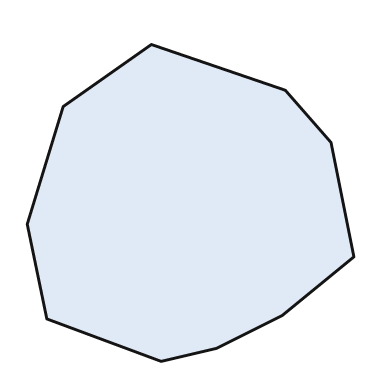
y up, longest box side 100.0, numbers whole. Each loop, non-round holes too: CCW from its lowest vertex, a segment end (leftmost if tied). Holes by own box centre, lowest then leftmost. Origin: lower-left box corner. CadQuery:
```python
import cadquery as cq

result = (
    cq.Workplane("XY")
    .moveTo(41.0, 0.0)
    .lineTo(58.0, 4.0)
    .lineTo(78.0, 14.0)
    .lineTo(100.0, 32.0)
    .lineTo(93.0, 67.0)
    .lineTo(79.0, 83.0)
    .lineTo(38.0, 97.0)
    .lineTo(11.0, 78.0)
    .lineTo(0.0, 42.0)
    .lineTo(6.0, 13.0)
    .close()
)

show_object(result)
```